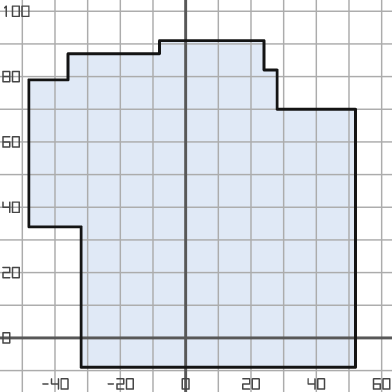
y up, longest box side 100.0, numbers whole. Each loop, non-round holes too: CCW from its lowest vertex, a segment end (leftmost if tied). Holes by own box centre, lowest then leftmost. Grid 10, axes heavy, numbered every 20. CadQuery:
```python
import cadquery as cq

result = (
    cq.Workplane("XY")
    .moveTo(-32.0, -9.0)
    .lineTo(52.0, -9.0)
    .lineTo(52.0, 70.0)
    .lineTo(28.0, 70.0)
    .lineTo(28.0, 82.0)
    .lineTo(24.0, 82.0)
    .lineTo(24.0, 91.0)
    .lineTo(-8.0, 91.0)
    .lineTo(-8.0, 87.0)
    .lineTo(-36.0, 87.0)
    .lineTo(-36.0, 79.0)
    .lineTo(-48.0, 79.0)
    .lineTo(-48.0, 34.0)
    .lineTo(-32.0, 34.0)
    .close()
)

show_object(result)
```